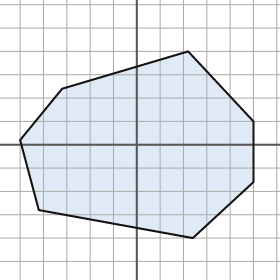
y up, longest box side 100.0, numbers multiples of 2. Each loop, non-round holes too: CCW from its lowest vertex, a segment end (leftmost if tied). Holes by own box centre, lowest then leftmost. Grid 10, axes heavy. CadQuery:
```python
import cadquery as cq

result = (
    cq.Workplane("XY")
    .moveTo(24.0, -40.0)
    .lineTo(50.0, -16.0)
    .lineTo(50.0, 10.0)
    .lineTo(22.0, 40.0)
    .lineTo(-32.0, 24.0)
    .lineTo(-50.0, 2.0)
    .lineTo(-42.0, -28.0)
    .close()
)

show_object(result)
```